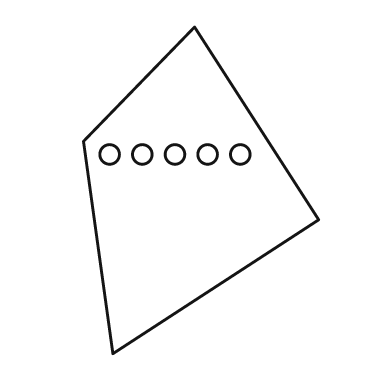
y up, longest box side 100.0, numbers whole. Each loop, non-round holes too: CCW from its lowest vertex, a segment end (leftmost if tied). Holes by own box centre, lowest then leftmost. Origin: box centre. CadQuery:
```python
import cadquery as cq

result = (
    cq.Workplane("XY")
    .moveTo(-27.0, -50.0)
    .lineTo(36.0, -9.0)
    .lineTo(-2.0, 50.0)
    .lineTo(-36.0, 15.0)
    .close()
    .moveTo(-28.0, 11.0)
    .circle(3.0)
    .moveTo(-18.0, 11.0)
    .circle(3.0)
    .moveTo(-8.0, 11.0)
    .circle(3.0)
    .moveTo(2.0, 11.0)
    .circle(3.0)
    .moveTo(12.0, 11.0)
    .circle(3.0)
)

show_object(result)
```